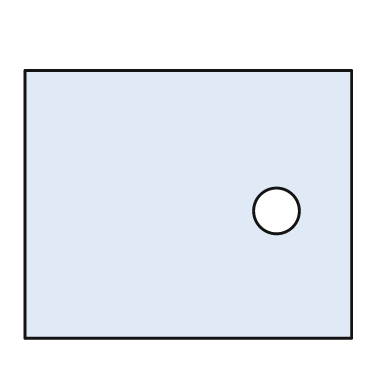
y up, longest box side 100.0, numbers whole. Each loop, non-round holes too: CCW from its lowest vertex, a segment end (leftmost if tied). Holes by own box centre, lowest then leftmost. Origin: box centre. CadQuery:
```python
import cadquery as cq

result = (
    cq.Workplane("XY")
    .moveTo(-50.0, -41.0)
    .lineTo(50.0, -41.0)
    .lineTo(50.0, 41.0)
    .lineTo(-50.0, 41.0)
    .close()
    .moveTo(27.0, -2.0)
    .circle(7.0)
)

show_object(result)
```